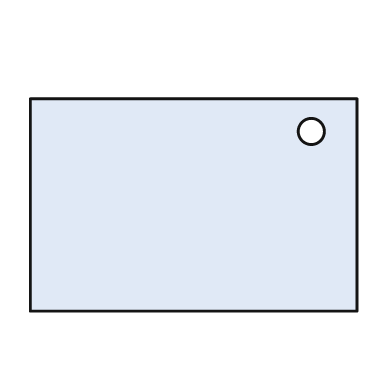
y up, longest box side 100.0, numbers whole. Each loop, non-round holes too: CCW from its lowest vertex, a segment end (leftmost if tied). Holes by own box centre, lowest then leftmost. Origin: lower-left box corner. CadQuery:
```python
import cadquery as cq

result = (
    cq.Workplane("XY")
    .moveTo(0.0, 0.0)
    .lineTo(100.0, 0.0)
    .lineTo(100.0, 65.0)
    .lineTo(0.0, 65.0)
    .close()
    .moveTo(86.0, 55.0)
    .circle(4.0)
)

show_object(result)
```